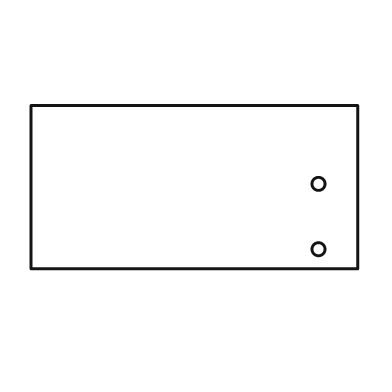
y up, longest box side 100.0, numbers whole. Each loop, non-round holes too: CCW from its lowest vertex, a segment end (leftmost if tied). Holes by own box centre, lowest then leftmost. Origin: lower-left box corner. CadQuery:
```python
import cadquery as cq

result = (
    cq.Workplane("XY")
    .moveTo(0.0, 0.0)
    .lineTo(100.0, 0.0)
    .lineTo(100.0, 50.0)
    .lineTo(0.0, 50.0)
    .close()
    .moveTo(88.0, 6.0)
    .circle(2.0)
    .moveTo(88.0, 26.0)
    .circle(2.0)
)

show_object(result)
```